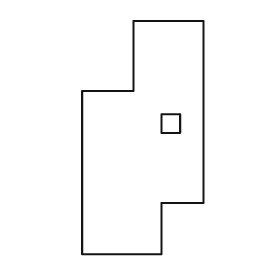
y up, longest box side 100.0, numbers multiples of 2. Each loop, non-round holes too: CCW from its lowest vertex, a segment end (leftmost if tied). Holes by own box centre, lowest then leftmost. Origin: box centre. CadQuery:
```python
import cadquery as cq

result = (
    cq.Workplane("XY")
    .moveTo(-26.0, -50.0)
    .lineTo(8.0, -50.0)
    .lineTo(8.0, -28.0)
    .lineTo(26.0, -28.0)
    .lineTo(26.0, 50.0)
    .lineTo(-4.0, 50.0)
    .lineTo(-4.0, 20.0)
    .lineTo(-26.0, 20.0)
    .close()
    .moveTo(8.0, 2.0)
    .lineTo(16.0, 2.0)
    .lineTo(16.0, 10.0)
    .lineTo(8.0, 10.0)
    .close()
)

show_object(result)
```